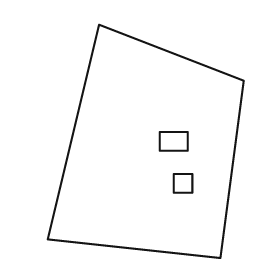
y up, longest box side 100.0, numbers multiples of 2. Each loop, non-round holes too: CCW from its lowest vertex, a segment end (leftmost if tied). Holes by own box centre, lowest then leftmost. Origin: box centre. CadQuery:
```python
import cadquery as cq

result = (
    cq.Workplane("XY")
    .moveTo(32.0, -50.0)
    .lineTo(42.0, 26.0)
    .lineTo(-20.0, 50.0)
    .lineTo(-42.0, -42.0)
    .close()
    .moveTo(12.0, -22.0)
    .lineTo(20.0, -22.0)
    .lineTo(20.0, -14.0)
    .lineTo(12.0, -14.0)
    .close()
    .moveTo(6.0, -4.0)
    .lineTo(18.0, -4.0)
    .lineTo(18.0, 4.0)
    .lineTo(6.0, 4.0)
    .close()
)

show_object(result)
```